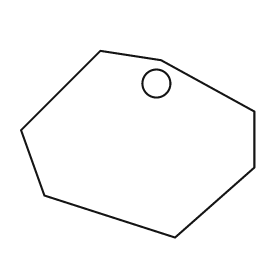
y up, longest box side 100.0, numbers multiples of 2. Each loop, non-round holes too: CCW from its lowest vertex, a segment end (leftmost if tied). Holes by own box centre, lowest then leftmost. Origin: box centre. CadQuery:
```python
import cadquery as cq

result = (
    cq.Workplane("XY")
    .moveTo(16.0, -40.0)
    .lineTo(50.0, -10.0)
    .lineTo(50.0, 14.0)
    .lineTo(10.0, 36.0)
    .lineTo(-16.0, 40.0)
    .lineTo(-50.0, 6.0)
    .lineTo(-40.0, -22.0)
    .close()
    .moveTo(8.0, 26.0)
    .circle(6.0)
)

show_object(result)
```